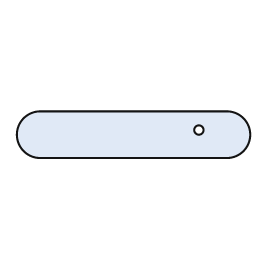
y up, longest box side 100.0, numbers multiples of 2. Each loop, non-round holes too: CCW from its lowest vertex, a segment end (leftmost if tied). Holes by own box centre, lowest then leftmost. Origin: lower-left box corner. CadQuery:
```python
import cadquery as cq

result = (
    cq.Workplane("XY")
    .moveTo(10.0, 0.0)
    .lineTo(90.0, 0.0)
    .threePointArc((100.0, 10.0), (90.0, 20.0))
    .lineTo(10.0, 20.0)
    .threePointArc((0.0, 10.0), (10.0, 0.0))
    .close()
    .moveTo(78.0, 12.0)
    .circle(2.0)
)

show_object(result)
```